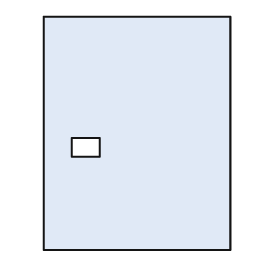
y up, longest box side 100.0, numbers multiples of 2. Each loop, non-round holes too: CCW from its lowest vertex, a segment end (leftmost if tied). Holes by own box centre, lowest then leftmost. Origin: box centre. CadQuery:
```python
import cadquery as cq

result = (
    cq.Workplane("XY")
    .moveTo(-40.0, -50.0)
    .lineTo(40.0, -50.0)
    .lineTo(40.0, 50.0)
    .lineTo(-40.0, 50.0)
    .close()
    .moveTo(-28.0, -10.0)
    .lineTo(-16.0, -10.0)
    .lineTo(-16.0, -2.0)
    .lineTo(-28.0, -2.0)
    .close()
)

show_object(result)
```